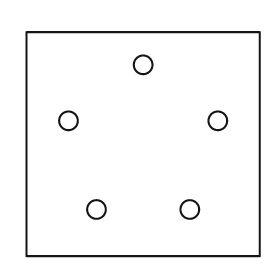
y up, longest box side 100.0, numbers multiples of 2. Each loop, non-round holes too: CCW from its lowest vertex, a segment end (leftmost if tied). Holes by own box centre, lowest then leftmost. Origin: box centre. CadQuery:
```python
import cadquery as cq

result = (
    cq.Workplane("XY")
    .moveTo(-50.0, -48.0)
    .lineTo(50.0, -48.0)
    .lineTo(50.0, 48.0)
    .lineTo(-50.0, 48.0)
    .close()
    .moveTo(-20.0, -28.0)
    .circle(4.0)
    .moveTo(20.0, -28.0)
    .circle(4.0)
    .moveTo(-32.0, 10.0)
    .circle(4.0)
    .moveTo(32.0, 10.0)
    .circle(4.0)
    .moveTo(0.0, 34.0)
    .circle(4.0)
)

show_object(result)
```